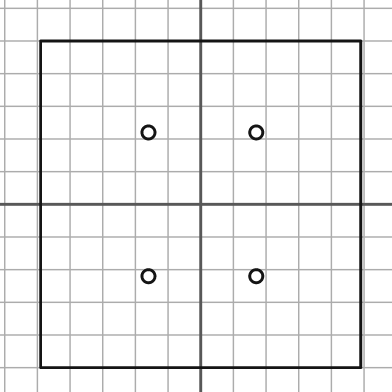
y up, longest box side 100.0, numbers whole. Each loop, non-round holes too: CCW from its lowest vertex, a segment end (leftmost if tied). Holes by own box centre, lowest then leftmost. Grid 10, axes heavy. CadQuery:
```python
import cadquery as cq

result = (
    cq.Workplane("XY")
    .moveTo(-49.0, -50.0)
    .lineTo(49.0, -50.0)
    .lineTo(49.0, 50.0)
    .lineTo(-49.0, 50.0)
    .close()
    .moveTo(-16.0, -22.0)
    .circle(2.0)
    .moveTo(17.0, -22.0)
    .circle(2.0)
    .moveTo(-16.0, 22.0)
    .circle(2.0)
    .moveTo(17.0, 22.0)
    .circle(2.0)
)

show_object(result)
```